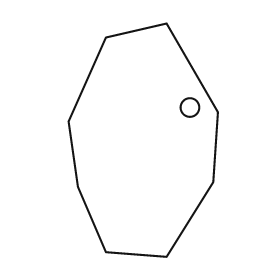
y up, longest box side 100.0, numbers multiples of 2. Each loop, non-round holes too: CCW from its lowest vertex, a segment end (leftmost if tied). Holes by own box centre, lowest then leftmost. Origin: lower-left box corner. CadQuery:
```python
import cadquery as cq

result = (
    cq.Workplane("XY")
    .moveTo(42.0, 0.0)
    .lineTo(62.0, 32.0)
    .lineTo(64.0, 62.0)
    .lineTo(42.0, 100.0)
    .lineTo(16.0, 94.0)
    .lineTo(0.0, 58.0)
    .lineTo(4.0, 30.0)
    .lineTo(16.0, 2.0)
    .close()
    .moveTo(52.0, 64.0)
    .circle(4.0)
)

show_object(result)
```